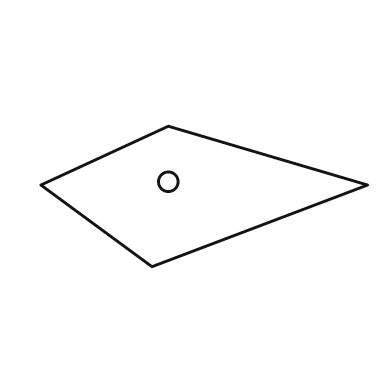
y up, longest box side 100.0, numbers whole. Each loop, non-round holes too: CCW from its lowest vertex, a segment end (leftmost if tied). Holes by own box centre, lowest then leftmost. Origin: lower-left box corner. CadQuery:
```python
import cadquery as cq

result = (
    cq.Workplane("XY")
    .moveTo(34.0, 0.0)
    .lineTo(100.0, 25.0)
    .lineTo(39.0, 43.0)
    .lineTo(0.0, 25.0)
    .close()
    .moveTo(39.0, 26.0)
    .circle(3.0)
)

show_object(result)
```